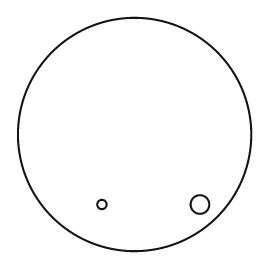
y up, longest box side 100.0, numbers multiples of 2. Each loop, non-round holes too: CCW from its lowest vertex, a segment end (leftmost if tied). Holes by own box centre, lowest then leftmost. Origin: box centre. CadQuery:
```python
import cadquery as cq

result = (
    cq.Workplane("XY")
    .moveTo(0.0, 0.0)
    .circle(50.0)
    .moveTo(-14.0, -30.0)
    .circle(2.0)
    .moveTo(28.0, -30.0)
    .circle(4.0)
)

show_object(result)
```